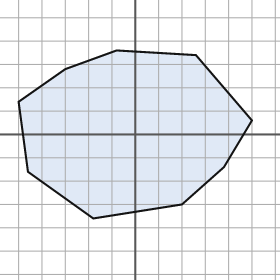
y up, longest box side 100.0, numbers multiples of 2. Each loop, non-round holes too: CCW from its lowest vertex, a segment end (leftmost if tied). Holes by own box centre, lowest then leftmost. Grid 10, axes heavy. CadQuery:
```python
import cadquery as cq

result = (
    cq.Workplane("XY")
    .moveTo(-18.0, -36.0)
    .lineTo(20.0, -30.0)
    .lineTo(38.0, -14.0)
    .lineTo(50.0, 6.0)
    .lineTo(26.0, 34.0)
    .lineTo(-8.0, 36.0)
    .lineTo(-30.0, 28.0)
    .lineTo(-50.0, 14.0)
    .lineTo(-46.0, -16.0)
    .close()
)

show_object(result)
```